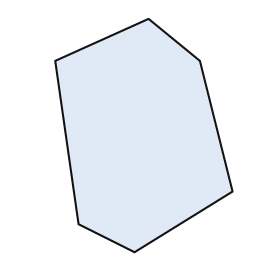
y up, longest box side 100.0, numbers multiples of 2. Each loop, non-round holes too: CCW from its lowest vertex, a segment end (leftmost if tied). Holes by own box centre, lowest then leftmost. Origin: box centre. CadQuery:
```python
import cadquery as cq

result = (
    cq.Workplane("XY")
    .moveTo(-4.0, -50.0)
    .lineTo(38.0, -24.0)
    .lineTo(24.0, 32.0)
    .lineTo(2.0, 50.0)
    .lineTo(-38.0, 32.0)
    .lineTo(-28.0, -38.0)
    .close()
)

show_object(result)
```